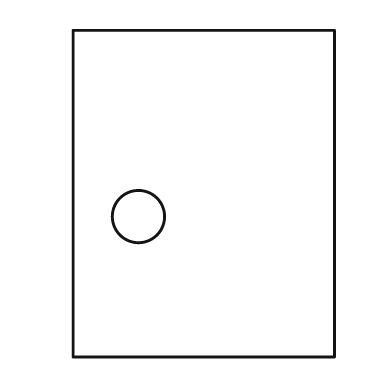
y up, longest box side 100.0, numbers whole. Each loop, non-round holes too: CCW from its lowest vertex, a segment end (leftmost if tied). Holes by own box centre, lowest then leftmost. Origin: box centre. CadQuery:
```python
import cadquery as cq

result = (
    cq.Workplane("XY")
    .moveTo(-40.0, -50.0)
    .lineTo(40.0, -50.0)
    .lineTo(40.0, 50.0)
    .lineTo(-40.0, 50.0)
    .close()
    .moveTo(-20.0, -7.0)
    .circle(8.0)
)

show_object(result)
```